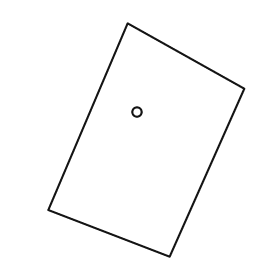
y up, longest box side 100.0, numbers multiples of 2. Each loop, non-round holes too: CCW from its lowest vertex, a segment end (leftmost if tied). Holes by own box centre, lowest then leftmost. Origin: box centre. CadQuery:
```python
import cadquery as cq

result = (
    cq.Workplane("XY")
    .moveTo(10.0, -50.0)
    .lineTo(42.0, 22.0)
    .lineTo(-8.0, 50.0)
    .lineTo(-42.0, -30.0)
    .close()
    .moveTo(-4.0, 12.0)
    .circle(2.0)
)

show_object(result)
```